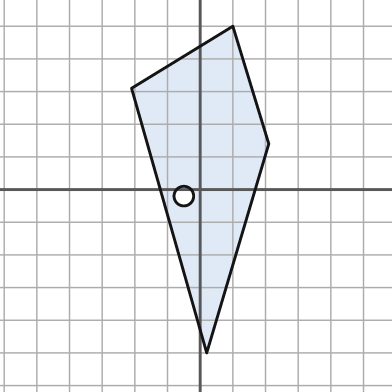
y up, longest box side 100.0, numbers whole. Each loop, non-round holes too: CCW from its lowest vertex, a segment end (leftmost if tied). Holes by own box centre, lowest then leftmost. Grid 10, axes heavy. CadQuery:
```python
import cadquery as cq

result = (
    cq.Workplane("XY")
    .moveTo(2.0, -50.0)
    .lineTo(21.0, 14.0)
    .lineTo(10.0, 50.0)
    .lineTo(-21.0, 31.0)
    .close()
    .moveTo(-5.0, -2.0)
    .circle(3.0)
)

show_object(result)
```